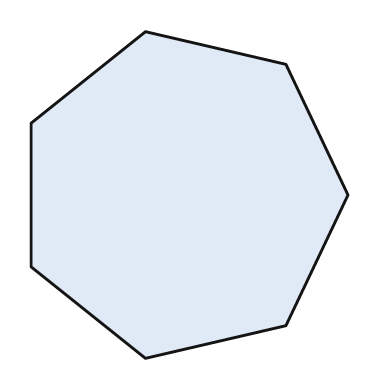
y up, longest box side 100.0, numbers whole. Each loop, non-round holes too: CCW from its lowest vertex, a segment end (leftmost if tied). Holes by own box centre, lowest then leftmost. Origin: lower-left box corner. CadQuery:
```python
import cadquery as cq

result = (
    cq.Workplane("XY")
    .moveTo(35.0, 0.0)
    .lineTo(78.0, 10.0)
    .lineTo(97.0, 50.0)
    .lineTo(78.0, 90.0)
    .lineTo(35.0, 100.0)
    .lineTo(0.0, 72.0)
    .lineTo(0.0, 28.0)
    .close()
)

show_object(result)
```